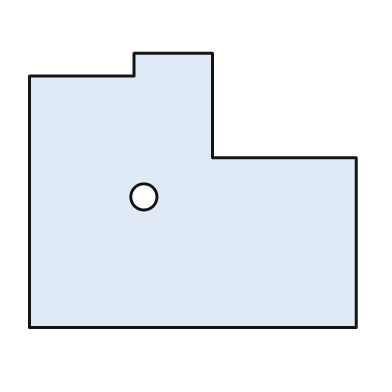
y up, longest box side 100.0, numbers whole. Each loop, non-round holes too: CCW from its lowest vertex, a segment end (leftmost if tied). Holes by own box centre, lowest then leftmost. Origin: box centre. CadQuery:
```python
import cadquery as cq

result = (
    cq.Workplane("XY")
    .moveTo(-50.0, -42.0)
    .lineTo(50.0, -42.0)
    .lineTo(50.0, 10.0)
    .lineTo(6.0, 10.0)
    .lineTo(6.0, 42.0)
    .lineTo(-18.0, 42.0)
    .lineTo(-18.0, 35.0)
    .lineTo(-50.0, 35.0)
    .close()
    .moveTo(-15.0, -2.0)
    .circle(4.0)
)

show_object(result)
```